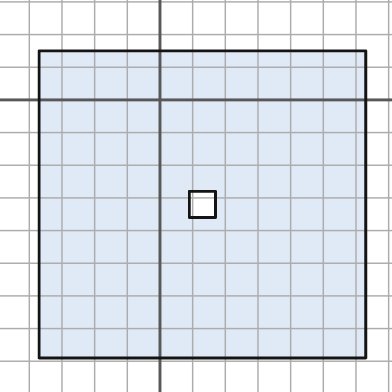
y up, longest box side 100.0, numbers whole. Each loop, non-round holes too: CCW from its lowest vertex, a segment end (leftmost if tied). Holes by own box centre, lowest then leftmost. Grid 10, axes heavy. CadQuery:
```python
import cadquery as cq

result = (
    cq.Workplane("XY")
    .moveTo(-37.0, -79.0)
    .lineTo(63.0, -79.0)
    .lineTo(63.0, 15.0)
    .lineTo(-37.0, 15.0)
    .close()
    .moveTo(9.0, -36.0)
    .lineTo(17.0, -36.0)
    .lineTo(17.0, -28.0)
    .lineTo(9.0, -28.0)
    .close()
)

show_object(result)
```